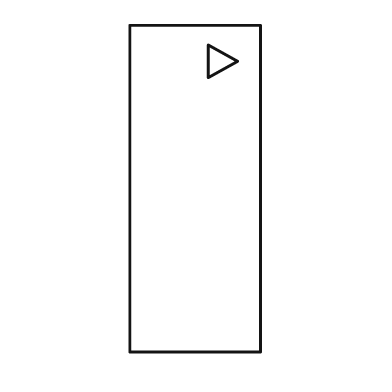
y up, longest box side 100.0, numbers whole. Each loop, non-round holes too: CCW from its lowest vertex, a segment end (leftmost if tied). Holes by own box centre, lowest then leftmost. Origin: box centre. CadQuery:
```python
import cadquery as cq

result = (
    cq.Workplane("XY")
    .moveTo(-20.0, -50.0)
    .lineTo(20.0, -50.0)
    .lineTo(20.0, 50.0)
    .lineTo(-20.0, 50.0)
    .close()
    .moveTo(4.0, 34.0)
    .lineTo(13.0, 39.0)
    .lineTo(4.0, 44.0)
    .close()
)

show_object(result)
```